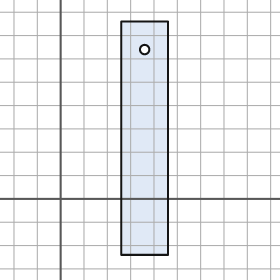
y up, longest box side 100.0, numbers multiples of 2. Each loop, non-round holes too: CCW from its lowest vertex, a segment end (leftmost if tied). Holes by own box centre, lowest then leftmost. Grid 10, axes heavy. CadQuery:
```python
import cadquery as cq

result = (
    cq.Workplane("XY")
    .moveTo(26.0, -24.0)
    .lineTo(46.0, -24.0)
    .lineTo(46.0, 76.0)
    .lineTo(26.0, 76.0)
    .close()
    .moveTo(36.0, 64.0)
    .circle(2.0)
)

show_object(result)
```